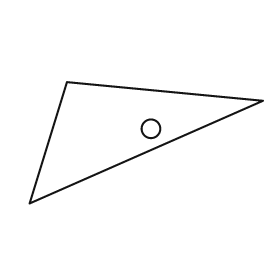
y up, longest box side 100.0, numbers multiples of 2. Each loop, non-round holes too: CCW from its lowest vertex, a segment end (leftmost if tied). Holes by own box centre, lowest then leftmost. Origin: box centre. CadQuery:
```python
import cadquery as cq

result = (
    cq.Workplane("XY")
    .moveTo(-50.0, -26.0)
    .lineTo(50.0, 18.0)
    .lineTo(-34.0, 26.0)
    .close()
    .moveTo(2.0, 6.0)
    .circle(4.0)
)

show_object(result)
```